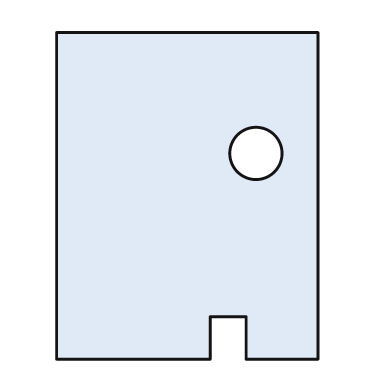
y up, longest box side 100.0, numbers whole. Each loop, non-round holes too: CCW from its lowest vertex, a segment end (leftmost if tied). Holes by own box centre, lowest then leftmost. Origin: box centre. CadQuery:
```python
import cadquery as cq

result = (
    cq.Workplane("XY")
    .moveTo(-40.0, -50.0)
    .lineTo(7.0, -50.0)
    .lineTo(7.0, -37.0)
    .lineTo(18.0, -37.0)
    .lineTo(18.0, -50.0)
    .lineTo(40.0, -50.0)
    .lineTo(40.0, 50.0)
    .lineTo(-40.0, 50.0)
    .close()
    .moveTo(21.0, 13.0)
    .circle(8.0)
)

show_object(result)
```